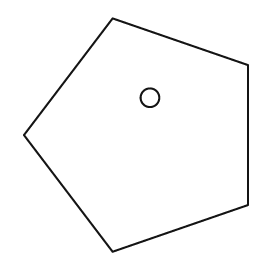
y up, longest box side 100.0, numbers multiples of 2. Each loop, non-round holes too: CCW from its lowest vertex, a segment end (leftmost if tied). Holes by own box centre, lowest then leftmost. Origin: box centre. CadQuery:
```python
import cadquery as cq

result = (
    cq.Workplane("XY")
    .moveTo(-10.0, -50.0)
    .lineTo(48.0, -30.0)
    .lineTo(48.0, 30.0)
    .lineTo(-10.0, 50.0)
    .lineTo(-48.0, 0.0)
    .close()
    .moveTo(6.0, 16.0)
    .circle(4.0)
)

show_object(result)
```